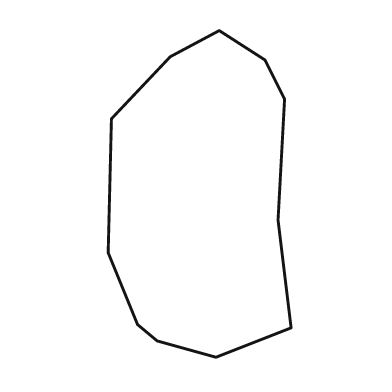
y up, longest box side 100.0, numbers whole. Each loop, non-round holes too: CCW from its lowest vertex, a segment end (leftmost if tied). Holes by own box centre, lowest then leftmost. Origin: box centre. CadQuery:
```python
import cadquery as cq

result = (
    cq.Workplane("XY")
    .moveTo(5.0, -50.0)
    .lineTo(28.0, -41.0)
    .lineTo(24.0, -8.0)
    .lineTo(26.0, 29.0)
    .lineTo(20.0, 41.0)
    .lineTo(6.0, 50.0)
    .lineTo(-9.0, 42.0)
    .lineTo(-27.0, 23.0)
    .lineTo(-28.0, -18.0)
    .lineTo(-19.0, -40.0)
    .lineTo(-13.0, -45.0)
    .close()
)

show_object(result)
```